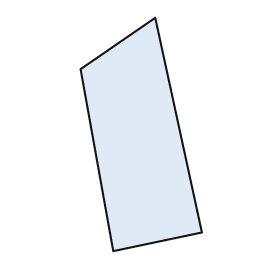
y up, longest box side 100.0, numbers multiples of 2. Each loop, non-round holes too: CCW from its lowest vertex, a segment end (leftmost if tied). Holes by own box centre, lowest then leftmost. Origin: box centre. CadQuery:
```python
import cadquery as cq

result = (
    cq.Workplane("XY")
    .moveTo(-12.0, -50.0)
    .lineTo(26.0, -42.0)
    .lineTo(6.0, 50.0)
    .lineTo(-26.0, 28.0)
    .close()
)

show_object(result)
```